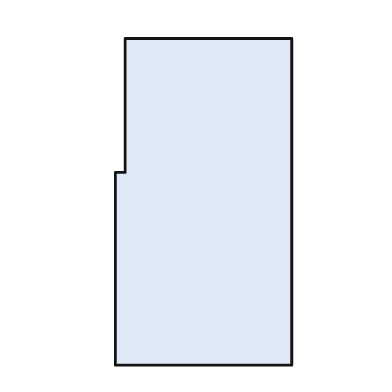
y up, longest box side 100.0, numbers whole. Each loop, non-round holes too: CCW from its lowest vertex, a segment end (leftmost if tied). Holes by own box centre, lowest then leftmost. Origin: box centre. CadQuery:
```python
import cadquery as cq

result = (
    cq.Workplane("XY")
    .moveTo(-27.0, -50.0)
    .lineTo(27.0, -50.0)
    .lineTo(27.0, 50.0)
    .lineTo(-24.0, 50.0)
    .lineTo(-24.0, 9.0)
    .lineTo(-27.0, 9.0)
    .close()
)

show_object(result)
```